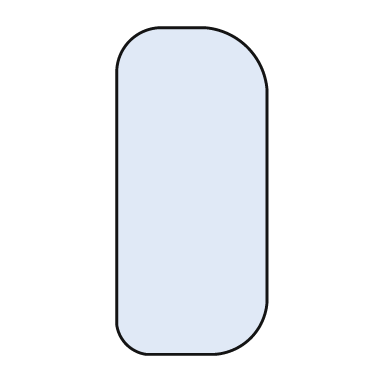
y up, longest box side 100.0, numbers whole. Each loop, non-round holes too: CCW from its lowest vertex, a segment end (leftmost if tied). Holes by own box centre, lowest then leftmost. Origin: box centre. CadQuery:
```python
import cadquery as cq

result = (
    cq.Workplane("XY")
    .moveTo(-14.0, -50.0)
    .lineTo(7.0, -50.0)
    .threePointArc((18.0, -45.0), (23.0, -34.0))
    .lineTo(23.0, 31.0)
    .threePointArc((17.0, 44.0), (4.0, 50.0))
    .lineTo(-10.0, 50.0)
    .threePointArc((-19.0, 46.0), (-23.0, 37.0))
    .lineTo(-23.0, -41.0)
    .threePointArc((-20.0, -47.0), (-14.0, -50.0))
    .close()
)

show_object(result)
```